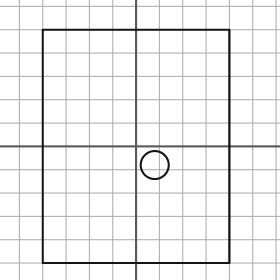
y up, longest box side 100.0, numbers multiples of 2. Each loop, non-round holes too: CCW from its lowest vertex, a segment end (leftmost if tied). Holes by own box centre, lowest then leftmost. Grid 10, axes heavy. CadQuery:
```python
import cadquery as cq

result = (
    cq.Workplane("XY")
    .moveTo(-40.0, -50.0)
    .lineTo(40.0, -50.0)
    .lineTo(40.0, 50.0)
    .lineTo(-40.0, 50.0)
    .close()
    .moveTo(8.0, -8.0)
    .circle(6.0)
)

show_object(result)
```